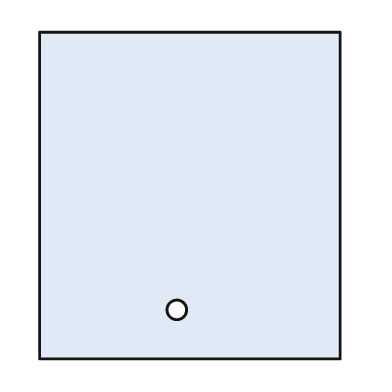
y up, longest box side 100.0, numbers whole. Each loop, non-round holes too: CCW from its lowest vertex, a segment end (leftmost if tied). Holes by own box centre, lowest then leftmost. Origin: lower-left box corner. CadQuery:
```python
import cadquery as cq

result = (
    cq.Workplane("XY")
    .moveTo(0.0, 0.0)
    .lineTo(92.0, 0.0)
    .lineTo(92.0, 100.0)
    .lineTo(0.0, 100.0)
    .close()
    .moveTo(42.0, 15.0)
    .circle(3.0)
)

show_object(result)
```